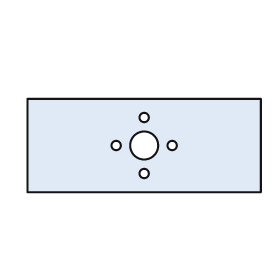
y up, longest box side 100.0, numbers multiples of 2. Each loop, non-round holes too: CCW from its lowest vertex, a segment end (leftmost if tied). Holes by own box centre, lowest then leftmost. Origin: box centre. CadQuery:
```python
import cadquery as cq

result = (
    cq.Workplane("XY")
    .moveTo(-50.0, -20.0)
    .lineTo(50.0, -20.0)
    .lineTo(50.0, 20.0)
    .lineTo(-50.0, 20.0)
    .close()
    .moveTo(0.0, -12.0)
    .circle(2.0)
    .moveTo(-12.0, 0.0)
    .circle(2.0)
    .moveTo(0.0, 0.0)
    .circle(6.0)
    .moveTo(12.0, 0.0)
    .circle(2.0)
    .moveTo(0.0, 12.0)
    .circle(2.0)
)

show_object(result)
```